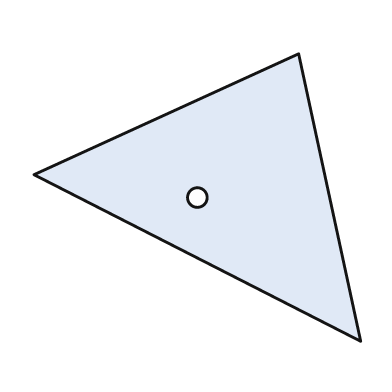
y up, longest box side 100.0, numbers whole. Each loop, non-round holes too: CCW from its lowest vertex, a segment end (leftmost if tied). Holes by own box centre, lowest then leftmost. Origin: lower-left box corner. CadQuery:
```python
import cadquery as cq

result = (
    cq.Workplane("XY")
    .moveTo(100.0, 0.0)
    .lineTo(81.0, 88.0)
    .lineTo(0.0, 51.0)
    .close()
    .moveTo(50.0, 44.0)
    .circle(3.0)
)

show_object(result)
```